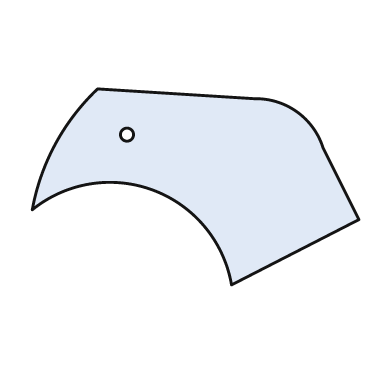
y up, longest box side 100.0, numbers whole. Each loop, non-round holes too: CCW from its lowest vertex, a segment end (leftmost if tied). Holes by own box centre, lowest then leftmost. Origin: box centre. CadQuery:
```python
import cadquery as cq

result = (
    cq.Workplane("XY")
    .moveTo(11.0, -30.0)
    .lineTo(50.0, -10.0)
    .lineTo(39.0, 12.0)
    .threePointArc((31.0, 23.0), (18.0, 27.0))
    .lineTo(-30.0, 30.0)
    .threePointArc((-43.0, 13.0), (-50.0, -7.0))
    .threePointArc((-13.0, -1.0), (11.0, -30.0))
    .close()
    .moveTo(-21.0, 16.0)
    .circle(2.0)
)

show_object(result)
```